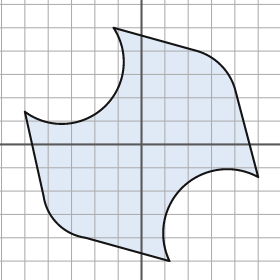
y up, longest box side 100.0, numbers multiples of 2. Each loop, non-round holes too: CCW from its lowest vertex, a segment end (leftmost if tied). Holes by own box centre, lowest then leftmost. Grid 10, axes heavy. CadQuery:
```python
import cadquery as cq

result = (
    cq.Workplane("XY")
    .moveTo(12.0, -50.0)
    .threePointArc((18.0, -18.0), (50.0, -14.0))
    .lineTo(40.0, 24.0)
    .threePointArc((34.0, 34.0), (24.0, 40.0))
    .lineTo(-12.0, 50.0)
    .threePointArc((-16.0, 16.0), (-50.0, 14.0))
    .lineTo(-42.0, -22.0)
    .threePointArc((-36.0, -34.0), (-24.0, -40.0))
    .close()
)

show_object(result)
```